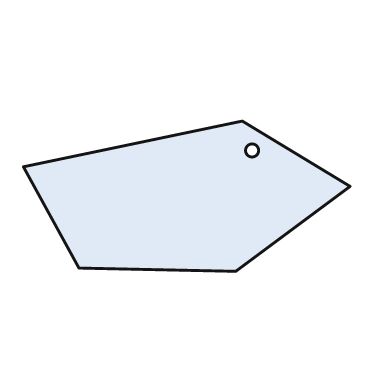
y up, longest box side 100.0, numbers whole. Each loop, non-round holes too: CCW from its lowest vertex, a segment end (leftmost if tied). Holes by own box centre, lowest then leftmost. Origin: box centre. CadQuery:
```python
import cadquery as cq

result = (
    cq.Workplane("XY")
    .moveTo(15.0, -23.0)
    .lineTo(50.0, 3.0)
    .lineTo(17.0, 23.0)
    .lineTo(-50.0, 9.0)
    .lineTo(-33.0, -22.0)
    .close()
    .moveTo(20.0, 14.0)
    .circle(2.0)
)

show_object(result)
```